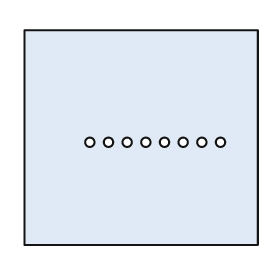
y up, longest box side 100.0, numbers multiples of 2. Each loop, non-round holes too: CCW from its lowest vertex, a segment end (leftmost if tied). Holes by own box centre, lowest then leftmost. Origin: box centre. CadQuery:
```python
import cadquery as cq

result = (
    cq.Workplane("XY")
    .moveTo(-50.0, -46.0)
    .lineTo(50.0, -46.0)
    .lineTo(50.0, 46.0)
    .lineTo(-50.0, 46.0)
    .close()
    .moveTo(-22.0, -2.0)
    .circle(2.0)
    .moveTo(-14.0, -2.0)
    .circle(2.0)
    .moveTo(-6.0, -2.0)
    .circle(2.0)
    .moveTo(2.0, -2.0)
    .circle(2.0)
    .moveTo(10.0, -2.0)
    .circle(2.0)
    .moveTo(18.0, -2.0)
    .circle(2.0)
    .moveTo(26.0, -2.0)
    .circle(2.0)
    .moveTo(34.0, -2.0)
    .circle(2.0)
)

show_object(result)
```